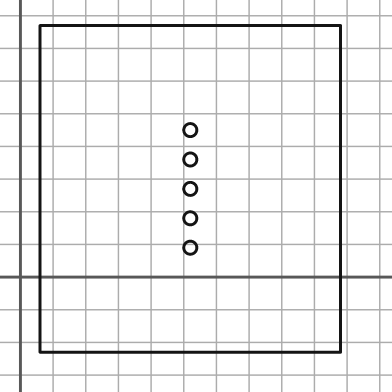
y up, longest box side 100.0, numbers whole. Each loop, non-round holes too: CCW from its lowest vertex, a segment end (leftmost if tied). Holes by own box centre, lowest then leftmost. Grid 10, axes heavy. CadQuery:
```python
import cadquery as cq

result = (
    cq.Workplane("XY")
    .moveTo(6.0, -23.0)
    .lineTo(98.0, -23.0)
    .lineTo(98.0, 77.0)
    .lineTo(6.0, 77.0)
    .close()
    .moveTo(52.0, 9.0)
    .circle(2.0)
    .moveTo(52.0, 18.0)
    .circle(2.0)
    .moveTo(52.0, 27.0)
    .circle(2.0)
    .moveTo(52.0, 36.0)
    .circle(2.0)
    .moveTo(52.0, 45.0)
    .circle(2.0)
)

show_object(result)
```